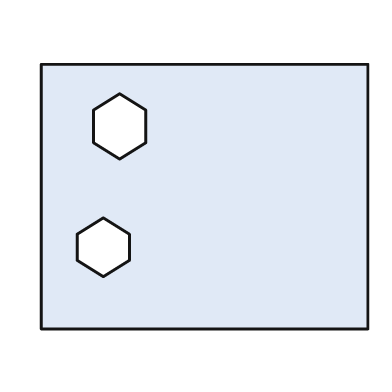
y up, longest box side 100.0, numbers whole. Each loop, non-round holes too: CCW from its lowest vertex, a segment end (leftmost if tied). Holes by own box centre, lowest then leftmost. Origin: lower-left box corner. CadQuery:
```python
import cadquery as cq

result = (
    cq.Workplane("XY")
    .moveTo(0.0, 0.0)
    .lineTo(100.0, 0.0)
    .lineTo(100.0, 81.0)
    .lineTo(0.0, 81.0)
    .close()
    .moveTo(19.0, 16.0)
    .lineTo(27.0, 21.0)
    .lineTo(27.0, 29.0)
    .lineTo(19.0, 34.0)
    .lineTo(11.0, 29.0)
    .lineTo(11.0, 21.0)
    .close()
    .moveTo(24.0, 52.0)
    .lineTo(32.0, 57.0)
    .lineTo(32.0, 67.0)
    .lineTo(24.0, 72.0)
    .lineTo(16.0, 67.0)
    .lineTo(16.0, 57.0)
    .close()
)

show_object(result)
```